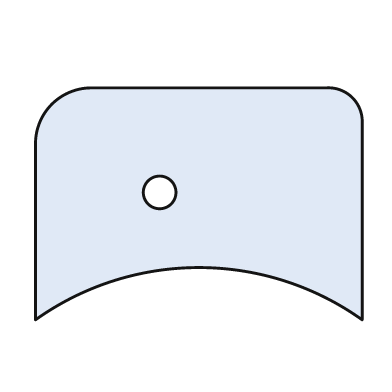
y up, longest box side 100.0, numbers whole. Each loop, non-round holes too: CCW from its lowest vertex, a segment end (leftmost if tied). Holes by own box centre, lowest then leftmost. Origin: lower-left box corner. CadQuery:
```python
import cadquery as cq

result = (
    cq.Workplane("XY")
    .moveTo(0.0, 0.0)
    .threePointArc((50.0, 16.0), (100.0, 0.0))
    .lineTo(100.0, 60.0)
    .threePointArc((97.0, 68.0), (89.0, 71.0))
    .lineTo(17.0, 71.0)
    .threePointArc((5.0, 66.0), (0.0, 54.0))
    .close()
    .moveTo(38.0, 39.0)
    .circle(5.0)
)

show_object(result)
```